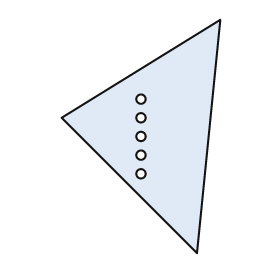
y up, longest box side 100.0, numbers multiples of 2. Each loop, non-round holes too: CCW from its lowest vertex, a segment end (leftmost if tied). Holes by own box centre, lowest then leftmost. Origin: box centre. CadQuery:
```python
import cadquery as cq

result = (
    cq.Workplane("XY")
    .moveTo(24.0, -50.0)
    .lineTo(34.0, 50.0)
    .lineTo(-34.0, 8.0)
    .close()
    .moveTo(0.0, -16.0)
    .circle(2.0)
    .moveTo(0.0, -8.0)
    .circle(2.0)
    .moveTo(0.0, 0.0)
    .circle(2.0)
    .moveTo(0.0, 8.0)
    .circle(2.0)
    .moveTo(0.0, 16.0)
    .circle(2.0)
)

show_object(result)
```